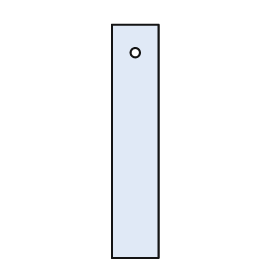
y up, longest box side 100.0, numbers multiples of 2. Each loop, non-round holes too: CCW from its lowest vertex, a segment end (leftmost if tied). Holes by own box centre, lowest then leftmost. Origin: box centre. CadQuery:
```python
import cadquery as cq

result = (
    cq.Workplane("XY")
    .moveTo(-10.0, -50.0)
    .lineTo(10.0, -50.0)
    .lineTo(10.0, 50.0)
    .lineTo(-10.0, 50.0)
    .close()
    .moveTo(0.0, 38.0)
    .circle(2.0)
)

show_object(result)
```